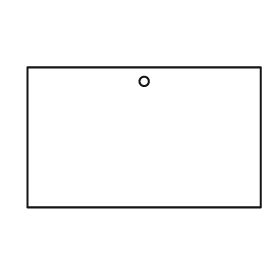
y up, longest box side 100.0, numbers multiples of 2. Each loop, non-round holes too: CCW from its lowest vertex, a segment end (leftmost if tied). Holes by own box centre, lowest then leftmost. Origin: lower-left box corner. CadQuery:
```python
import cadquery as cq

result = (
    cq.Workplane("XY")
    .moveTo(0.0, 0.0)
    .lineTo(100.0, 0.0)
    .lineTo(100.0, 60.0)
    .lineTo(0.0, 60.0)
    .close()
    .moveTo(50.0, 54.0)
    .circle(2.0)
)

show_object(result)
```